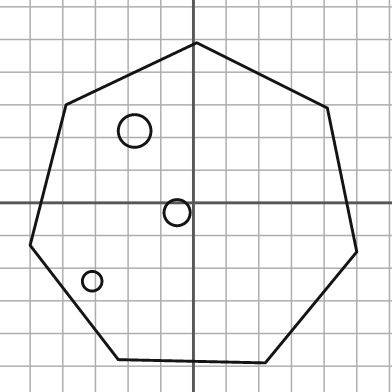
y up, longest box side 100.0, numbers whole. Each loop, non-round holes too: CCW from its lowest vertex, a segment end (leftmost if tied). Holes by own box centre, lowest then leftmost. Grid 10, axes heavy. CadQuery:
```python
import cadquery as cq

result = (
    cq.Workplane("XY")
    .moveTo(22.0, -49.0)
    .lineTo(50.0, -15.0)
    .lineTo(41.0, 29.0)
    .lineTo(1.0, 49.0)
    .lineTo(-39.0, 30.0)
    .lineTo(-50.0, -13.0)
    .lineTo(-23.0, -48.0)
    .close()
    .moveTo(-31.0, -24.0)
    .circle(3.0)
    .moveTo(-5.0, -3.0)
    .circle(4.0)
    .moveTo(-18.0, 22.0)
    .circle(5.0)
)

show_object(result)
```